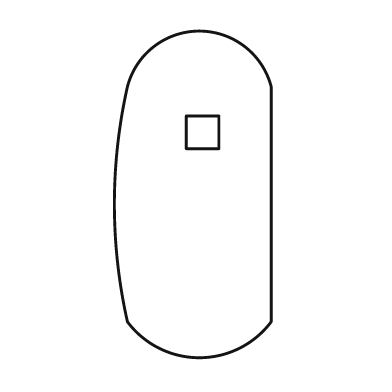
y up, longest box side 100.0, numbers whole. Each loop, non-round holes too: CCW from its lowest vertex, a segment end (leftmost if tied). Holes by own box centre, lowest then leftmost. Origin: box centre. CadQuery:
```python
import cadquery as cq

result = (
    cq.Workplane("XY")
    .moveTo(-20.0, -39.0)
    .threePointArc((2.0, -50.0), (24.0, -39.0))
    .lineTo(24.0, 33.0)
    .threePointArc((2.0, 50.0), (-20.0, 33.0))
    .threePointArc((-24.0, -3.0), (-20.0, -39.0))
    .close()
    .moveTo(-2.0, 14.0)
    .lineTo(8.0, 14.0)
    .lineTo(8.0, 24.0)
    .lineTo(-2.0, 24.0)
    .close()
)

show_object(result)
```